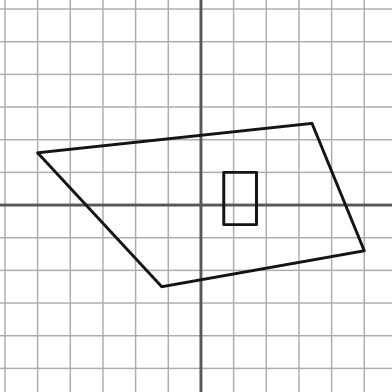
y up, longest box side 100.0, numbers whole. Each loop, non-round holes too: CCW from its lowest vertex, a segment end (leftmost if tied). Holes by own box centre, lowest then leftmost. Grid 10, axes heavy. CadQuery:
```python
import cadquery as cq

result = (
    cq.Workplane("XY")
    .moveTo(-12.0, -25.0)
    .lineTo(50.0, -14.0)
    .lineTo(34.0, 25.0)
    .lineTo(-50.0, 16.0)
    .close()
    .moveTo(7.0, -6.0)
    .lineTo(17.0, -6.0)
    .lineTo(17.0, 10.0)
    .lineTo(7.0, 10.0)
    .close()
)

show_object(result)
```